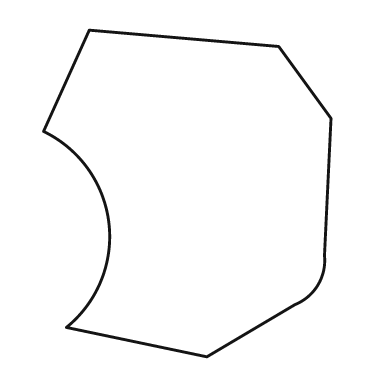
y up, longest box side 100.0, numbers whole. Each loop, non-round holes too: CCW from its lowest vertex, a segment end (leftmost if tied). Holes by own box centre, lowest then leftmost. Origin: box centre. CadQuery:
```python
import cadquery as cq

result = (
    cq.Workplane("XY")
    .moveTo(6.0, -50.0)
    .lineTo(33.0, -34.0)
    .threePointArc((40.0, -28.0), (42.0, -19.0))
    .lineTo(44.0, 23.0)
    .lineTo(28.0, 45.0)
    .lineTo(-30.0, 50.0)
    .lineTo(-44.0, 19.0)
    .threePointArc((-24.0, -9.0), (-37.0, -41.0))
    .close()
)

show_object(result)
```